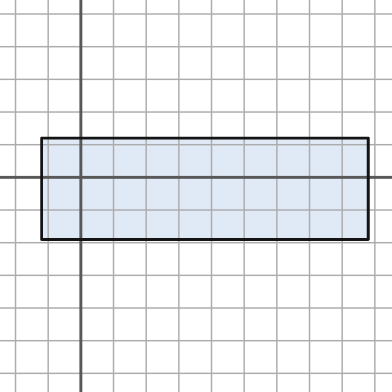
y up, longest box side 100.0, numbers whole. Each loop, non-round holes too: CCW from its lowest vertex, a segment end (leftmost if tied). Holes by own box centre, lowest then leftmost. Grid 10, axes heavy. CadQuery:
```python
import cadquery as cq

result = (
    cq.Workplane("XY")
    .moveTo(-12.0, -19.0)
    .lineTo(88.0, -19.0)
    .lineTo(88.0, 12.0)
    .lineTo(-12.0, 12.0)
    .close()
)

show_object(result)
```